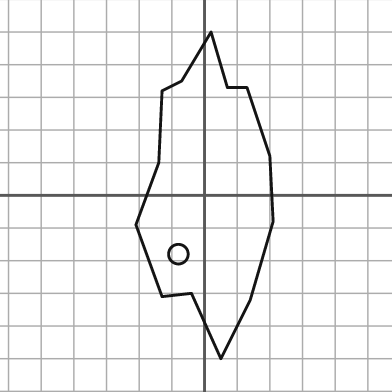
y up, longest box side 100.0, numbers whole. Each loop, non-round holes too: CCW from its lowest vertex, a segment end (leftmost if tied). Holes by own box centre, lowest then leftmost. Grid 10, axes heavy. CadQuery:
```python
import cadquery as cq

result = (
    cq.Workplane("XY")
    .moveTo(5.0, -50.0)
    .lineTo(14.0, -32.0)
    .lineTo(21.0, -8.0)
    .lineTo(20.0, 12.0)
    .lineTo(13.0, 33.0)
    .lineTo(7.0, 33.0)
    .lineTo(2.0, 50.0)
    .lineTo(-7.0, 35.0)
    .lineTo(-13.0, 32.0)
    .lineTo(-14.0, 10.0)
    .lineTo(-21.0, -9.0)
    .lineTo(-13.0, -31.0)
    .lineTo(-4.0, -30.0)
    .close()
    .moveTo(-8.0, -18.0)
    .circle(3.0)
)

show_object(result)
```